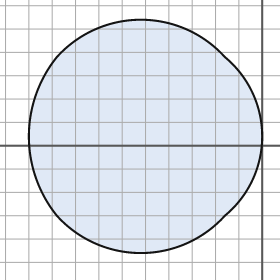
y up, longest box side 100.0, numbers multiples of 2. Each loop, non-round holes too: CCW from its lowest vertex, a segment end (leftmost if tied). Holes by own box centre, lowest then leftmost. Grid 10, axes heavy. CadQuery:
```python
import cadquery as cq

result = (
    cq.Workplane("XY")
    .moveTo(-88.0, -30.0)
    .threePointArc((-52.0, -46.0), (-16.0, -30.0))
    .threePointArc((0.0, 4.0), (-16.0, 38.0))
    .threePointArc((-52.0, 54.0), (-88.0, 38.0))
    .threePointArc((-100.0, 4.0), (-88.0, -30.0))
    .close()
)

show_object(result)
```